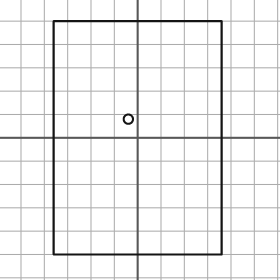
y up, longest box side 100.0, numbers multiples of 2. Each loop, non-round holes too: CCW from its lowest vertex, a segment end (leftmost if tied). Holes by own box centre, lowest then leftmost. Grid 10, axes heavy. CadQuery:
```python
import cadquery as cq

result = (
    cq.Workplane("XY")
    .moveTo(-36.0, -50.0)
    .lineTo(36.0, -50.0)
    .lineTo(36.0, 50.0)
    .lineTo(-36.0, 50.0)
    .close()
    .moveTo(-4.0, 8.0)
    .circle(2.0)
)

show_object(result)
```